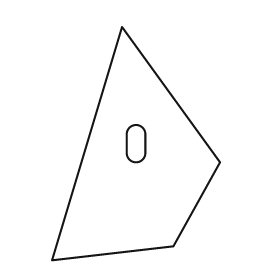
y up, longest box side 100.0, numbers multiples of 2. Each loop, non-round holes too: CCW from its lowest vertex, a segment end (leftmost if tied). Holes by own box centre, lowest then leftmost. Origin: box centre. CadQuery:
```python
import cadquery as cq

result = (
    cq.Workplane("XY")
    .moveTo(-36.0, -50.0)
    .lineTo(16.0, -44.0)
    .lineTo(36.0, -8.0)
    .lineTo(-6.0, 50.0)
    .close()
    .moveTo(-4.0, -4.0)
    .threePointArc((0.0, -8.0), (4.0, -4.0))
    .lineTo(4.0, 4.0)
    .threePointArc((0.0, 8.0), (-4.0, 4.0))
    .close()
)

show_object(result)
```